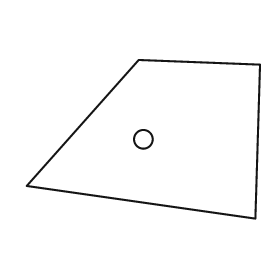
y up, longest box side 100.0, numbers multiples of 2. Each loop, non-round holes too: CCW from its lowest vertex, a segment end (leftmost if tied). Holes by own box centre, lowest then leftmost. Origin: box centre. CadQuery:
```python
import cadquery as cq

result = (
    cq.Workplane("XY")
    .moveTo(48.0, -34.0)
    .lineTo(50.0, 32.0)
    .lineTo(-2.0, 34.0)
    .lineTo(-50.0, -20.0)
    .close()
    .moveTo(0.0, 0.0)
    .circle(4.0)
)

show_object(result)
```